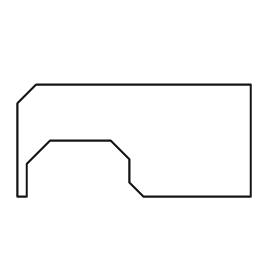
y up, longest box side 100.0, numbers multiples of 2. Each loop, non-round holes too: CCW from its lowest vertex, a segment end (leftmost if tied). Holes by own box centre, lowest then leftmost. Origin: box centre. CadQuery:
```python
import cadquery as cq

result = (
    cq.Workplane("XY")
    .moveTo(-50.0, -24.0)
    .lineTo(-46.0, -24.0)
    .lineTo(-46.0, -10.0)
    .lineTo(-36.0, 0.0)
    .lineTo(-10.0, 0.0)
    .lineTo(-2.0, -8.0)
    .lineTo(-2.0, -18.0)
    .lineTo(4.0, -24.0)
    .lineTo(50.0, -24.0)
    .lineTo(50.0, 24.0)
    .lineTo(-42.0, 24.0)
    .lineTo(-50.0, 16.0)
    .close()
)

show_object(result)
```